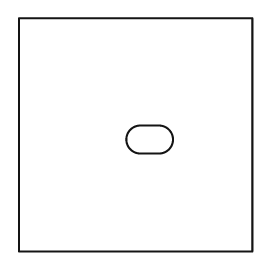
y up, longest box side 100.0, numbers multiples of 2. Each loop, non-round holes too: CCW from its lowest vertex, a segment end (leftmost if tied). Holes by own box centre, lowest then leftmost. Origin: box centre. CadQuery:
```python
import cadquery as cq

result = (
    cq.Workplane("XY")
    .moveTo(-50.0, -50.0)
    .lineTo(50.0, -50.0)
    .lineTo(50.0, 50.0)
    .lineTo(-50.0, 50.0)
    .close()
    .moveTo(2.0, -8.0)
    .lineTo(10.0, -8.0)
    .threePointArc((16.0, -2.0), (10.0, 4.0))
    .lineTo(2.0, 4.0)
    .threePointArc((-4.0, -2.0), (2.0, -8.0))
    .close()
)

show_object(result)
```